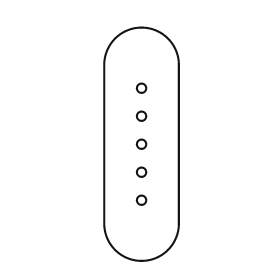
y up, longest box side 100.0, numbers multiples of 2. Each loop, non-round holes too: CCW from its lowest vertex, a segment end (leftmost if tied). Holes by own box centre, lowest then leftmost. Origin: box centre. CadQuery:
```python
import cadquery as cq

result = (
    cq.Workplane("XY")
    .moveTo(-16.0, -34.0)
    .threePointArc((0.0, -50.0), (16.0, -34.0))
    .lineTo(16.0, 34.0)
    .threePointArc((0.0, 50.0), (-16.0, 34.0))
    .close()
    .moveTo(0.0, -24.0)
    .circle(2.0)
    .moveTo(0.0, -12.0)
    .circle(2.0)
    .moveTo(0.0, 0.0)
    .circle(2.0)
    .moveTo(0.0, 12.0)
    .circle(2.0)
    .moveTo(0.0, 24.0)
    .circle(2.0)
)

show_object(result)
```